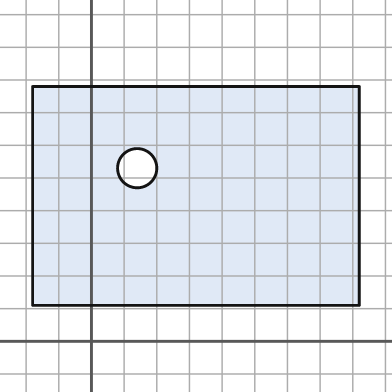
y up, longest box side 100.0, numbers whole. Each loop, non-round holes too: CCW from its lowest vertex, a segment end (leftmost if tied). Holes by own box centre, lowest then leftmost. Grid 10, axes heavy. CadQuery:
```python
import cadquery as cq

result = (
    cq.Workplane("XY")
    .moveTo(-18.0, 11.0)
    .lineTo(82.0, 11.0)
    .lineTo(82.0, 78.0)
    .lineTo(-18.0, 78.0)
    .close()
    .moveTo(14.0, 53.0)
    .circle(6.0)
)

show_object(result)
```